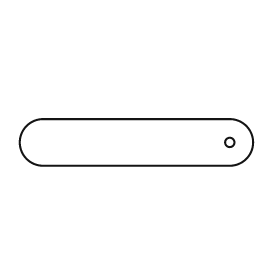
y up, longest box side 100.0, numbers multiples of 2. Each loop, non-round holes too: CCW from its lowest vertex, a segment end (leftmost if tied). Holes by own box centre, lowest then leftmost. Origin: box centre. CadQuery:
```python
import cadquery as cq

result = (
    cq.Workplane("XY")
    .moveTo(-40.0, -10.0)
    .lineTo(40.0, -10.0)
    .threePointArc((50.0, 0.0), (40.0, 10.0))
    .lineTo(-40.0, 10.0)
    .threePointArc((-50.0, 0.0), (-40.0, -10.0))
    .close()
    .moveTo(40.0, 0.0)
    .circle(2.0)
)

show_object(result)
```